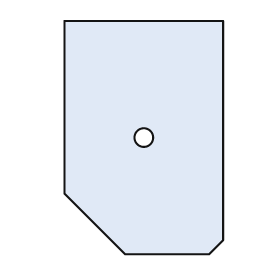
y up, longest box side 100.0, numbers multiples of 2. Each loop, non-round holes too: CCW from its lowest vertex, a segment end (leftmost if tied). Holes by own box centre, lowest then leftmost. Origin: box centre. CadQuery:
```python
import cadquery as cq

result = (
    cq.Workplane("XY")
    .moveTo(-8.0, -50.0)
    .lineTo(28.0, -50.0)
    .lineTo(34.0, -44.0)
    .lineTo(34.0, 50.0)
    .lineTo(-34.0, 50.0)
    .lineTo(-34.0, -24.0)
    .close()
    .moveTo(0.0, 0.0)
    .circle(4.0)
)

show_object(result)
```